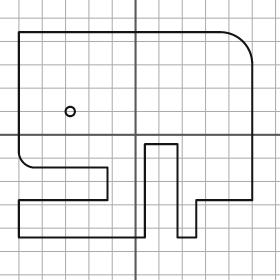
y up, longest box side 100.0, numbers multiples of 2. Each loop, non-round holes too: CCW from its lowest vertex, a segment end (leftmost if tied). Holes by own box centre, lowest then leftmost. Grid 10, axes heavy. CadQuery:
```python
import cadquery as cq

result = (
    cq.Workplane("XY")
    .moveTo(-50.0, -44.0)
    .lineTo(4.0, -44.0)
    .lineTo(4.0, -4.0)
    .lineTo(18.0, -4.0)
    .lineTo(18.0, -44.0)
    .lineTo(26.0, -44.0)
    .lineTo(26.0, -28.0)
    .lineTo(50.0, -28.0)
    .lineTo(50.0, 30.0)
    .threePointArc((46.0, 40.0), (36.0, 44.0))
    .lineTo(-50.0, 44.0)
    .lineTo(-50.0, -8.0)
    .threePointArc((-48.0, -12.0), (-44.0, -14.0))
    .lineTo(-12.0, -14.0)
    .lineTo(-12.0, -28.0)
    .lineTo(-50.0, -28.0)
    .close()
    .moveTo(-28.0, 10.0)
    .circle(2.0)
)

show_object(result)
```